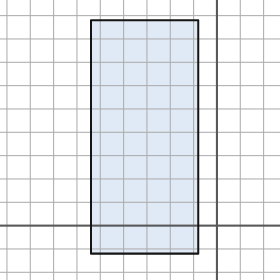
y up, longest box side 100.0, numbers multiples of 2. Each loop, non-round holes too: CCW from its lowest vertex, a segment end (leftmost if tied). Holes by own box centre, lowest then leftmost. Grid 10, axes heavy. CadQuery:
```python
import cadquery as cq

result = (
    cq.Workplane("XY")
    .moveTo(-54.0, -12.0)
    .lineTo(-8.0, -12.0)
    .lineTo(-8.0, 88.0)
    .lineTo(-54.0, 88.0)
    .close()
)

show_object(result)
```